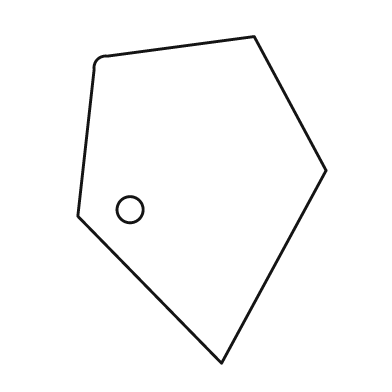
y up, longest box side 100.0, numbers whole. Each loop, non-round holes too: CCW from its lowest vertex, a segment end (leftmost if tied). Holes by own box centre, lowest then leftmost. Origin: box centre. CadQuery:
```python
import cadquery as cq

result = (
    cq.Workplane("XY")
    .moveTo(6.0, -50.0)
    .lineTo(38.0, 9.0)
    .lineTo(16.0, 50.0)
    .lineTo(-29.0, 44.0)
    .threePointArc((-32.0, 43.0), (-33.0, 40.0))
    .lineTo(-38.0, -5.0)
    .close()
    .moveTo(-22.0, -3.0)
    .circle(4.0)
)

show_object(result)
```